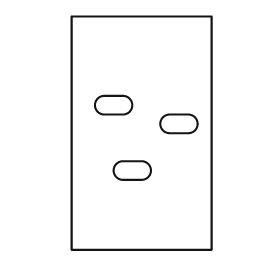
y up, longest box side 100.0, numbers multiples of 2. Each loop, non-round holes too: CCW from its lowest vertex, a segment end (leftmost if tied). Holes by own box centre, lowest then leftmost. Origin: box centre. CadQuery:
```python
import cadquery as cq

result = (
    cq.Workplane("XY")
    .moveTo(-30.0, -50.0)
    .lineTo(30.0, -50.0)
    .lineTo(30.0, 50.0)
    .lineTo(-30.0, 50.0)
    .close()
    .moveTo(-8.0, -20.0)
    .lineTo(0.0, -20.0)
    .threePointArc((4.0, -16.0), (0.0, -12.0))
    .lineTo(-8.0, -12.0)
    .threePointArc((-12.0, -16.0), (-8.0, -20.0))
    .close()
    .moveTo(12.0, 0.0)
    .lineTo(20.0, 0.0)
    .threePointArc((24.0, 4.0), (20.0, 8.0))
    .lineTo(12.0, 8.0)
    .threePointArc((8.0, 4.0), (12.0, 0.0))
    .close()
    .moveTo(-16.0, 8.0)
    .lineTo(-8.0, 8.0)
    .threePointArc((-4.0, 12.0), (-8.0, 16.0))
    .lineTo(-16.0, 16.0)
    .threePointArc((-20.0, 12.0), (-16.0, 8.0))
    .close()
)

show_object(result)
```